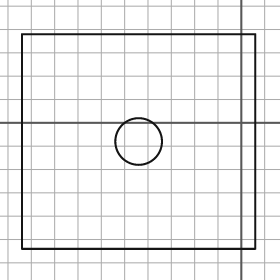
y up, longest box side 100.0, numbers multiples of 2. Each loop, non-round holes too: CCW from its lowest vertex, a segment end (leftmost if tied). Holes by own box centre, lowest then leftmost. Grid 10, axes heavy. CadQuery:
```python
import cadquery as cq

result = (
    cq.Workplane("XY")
    .moveTo(-94.0, -54.0)
    .lineTo(6.0, -54.0)
    .lineTo(6.0, 38.0)
    .lineTo(-94.0, 38.0)
    .close()
    .moveTo(-44.0, -8.0)
    .circle(10.0)
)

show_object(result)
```